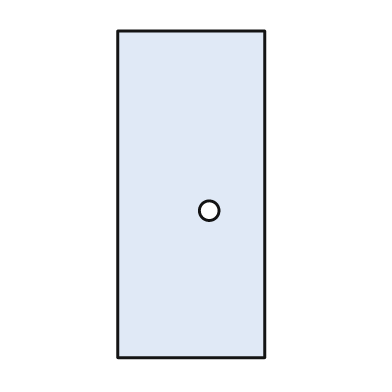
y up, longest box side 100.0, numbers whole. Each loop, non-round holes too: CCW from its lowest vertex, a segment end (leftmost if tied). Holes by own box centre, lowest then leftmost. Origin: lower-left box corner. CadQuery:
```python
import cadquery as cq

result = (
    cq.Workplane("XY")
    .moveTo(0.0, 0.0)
    .lineTo(45.0, 0.0)
    .lineTo(45.0, 100.0)
    .lineTo(0.0, 100.0)
    .close()
    .moveTo(28.0, 45.0)
    .circle(3.0)
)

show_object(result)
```